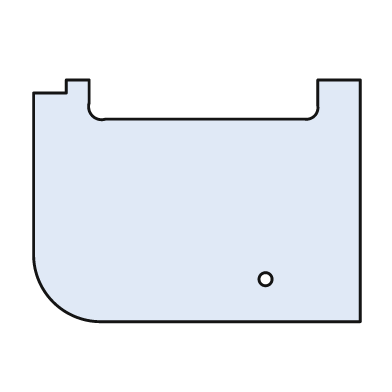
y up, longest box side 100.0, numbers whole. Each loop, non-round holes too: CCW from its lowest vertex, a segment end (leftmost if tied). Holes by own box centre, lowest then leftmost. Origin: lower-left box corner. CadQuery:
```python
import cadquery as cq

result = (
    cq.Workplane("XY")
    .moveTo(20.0, 0.0)
    .lineTo(100.0, 0.0)
    .lineTo(100.0, 74.0)
    .lineTo(87.0, 74.0)
    .lineTo(87.0, 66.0)
    .threePointArc((86.0, 63.0), (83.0, 62.0))
    .lineTo(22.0, 62.0)
    .threePointArc((18.0, 63.0), (17.0, 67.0))
    .lineTo(17.0, 74.0)
    .lineTo(10.0, 74.0)
    .lineTo(10.0, 70.0)
    .lineTo(0.0, 70.0)
    .lineTo(0.0, 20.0)
    .threePointArc((6.0, 6.0), (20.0, 0.0))
    .close()
    .moveTo(71.0, 13.0)
    .circle(2.0)
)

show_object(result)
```